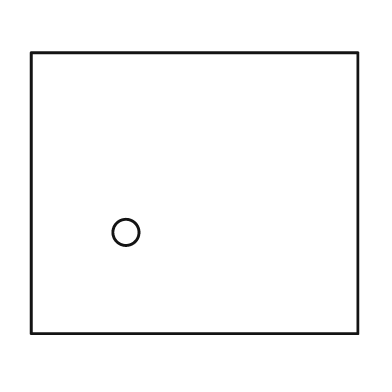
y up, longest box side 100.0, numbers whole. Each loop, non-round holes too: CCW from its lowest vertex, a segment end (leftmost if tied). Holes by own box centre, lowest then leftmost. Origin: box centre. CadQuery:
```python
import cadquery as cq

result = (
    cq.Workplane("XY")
    .moveTo(-50.0, -43.0)
    .lineTo(50.0, -43.0)
    .lineTo(50.0, 43.0)
    .lineTo(-50.0, 43.0)
    .close()
    .moveTo(-21.0, -12.0)
    .circle(4.0)
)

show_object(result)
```